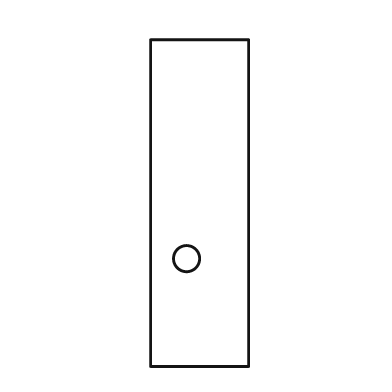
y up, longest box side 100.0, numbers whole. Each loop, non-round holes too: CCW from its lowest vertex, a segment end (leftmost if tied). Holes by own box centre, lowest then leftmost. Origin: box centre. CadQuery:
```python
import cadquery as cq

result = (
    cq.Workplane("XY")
    .moveTo(-15.0, -50.0)
    .lineTo(15.0, -50.0)
    .lineTo(15.0, 50.0)
    .lineTo(-15.0, 50.0)
    .close()
    .moveTo(-4.0, -17.0)
    .circle(4.0)
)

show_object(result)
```